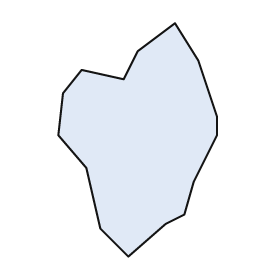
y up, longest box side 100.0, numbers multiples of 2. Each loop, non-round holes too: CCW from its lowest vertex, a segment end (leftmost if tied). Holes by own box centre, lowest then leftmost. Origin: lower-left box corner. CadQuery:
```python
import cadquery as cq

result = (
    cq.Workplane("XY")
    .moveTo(30.0, 0.0)
    .lineTo(46.0, 14.0)
    .lineTo(54.0, 18.0)
    .lineTo(58.0, 32.0)
    .lineTo(68.0, 52.0)
    .lineTo(68.0, 60.0)
    .lineTo(60.0, 84.0)
    .lineTo(50.0, 100.0)
    .lineTo(34.0, 88.0)
    .lineTo(28.0, 76.0)
    .lineTo(10.0, 80.0)
    .lineTo(2.0, 70.0)
    .lineTo(0.0, 52.0)
    .lineTo(12.0, 38.0)
    .lineTo(18.0, 12.0)
    .close()
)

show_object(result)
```